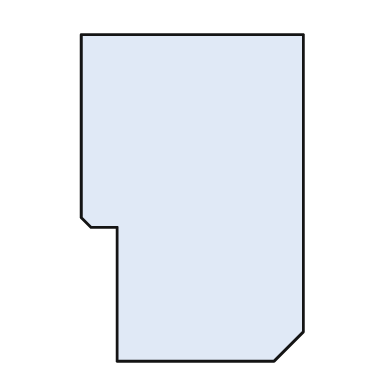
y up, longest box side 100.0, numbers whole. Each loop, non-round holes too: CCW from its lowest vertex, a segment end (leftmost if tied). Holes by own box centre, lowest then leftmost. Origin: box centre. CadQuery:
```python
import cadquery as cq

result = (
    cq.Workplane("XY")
    .moveTo(-23.0, -50.0)
    .lineTo(25.0, -50.0)
    .lineTo(34.0, -41.0)
    .lineTo(34.0, 50.0)
    .lineTo(-34.0, 50.0)
    .lineTo(-34.0, -6.0)
    .lineTo(-31.0, -9.0)
    .lineTo(-23.0, -9.0)
    .close()
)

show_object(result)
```